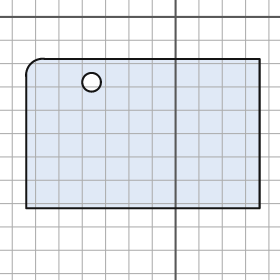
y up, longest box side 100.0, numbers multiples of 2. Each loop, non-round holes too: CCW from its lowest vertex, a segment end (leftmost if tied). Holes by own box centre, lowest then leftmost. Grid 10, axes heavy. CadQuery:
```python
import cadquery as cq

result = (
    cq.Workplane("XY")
    .moveTo(-64.0, -82.0)
    .lineTo(36.0, -82.0)
    .lineTo(36.0, -18.0)
    .lineTo(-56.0, -18.0)
    .threePointArc((-62.0, -20.0), (-64.0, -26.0))
    .close()
    .moveTo(-36.0, -28.0)
    .circle(4.0)
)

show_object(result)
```